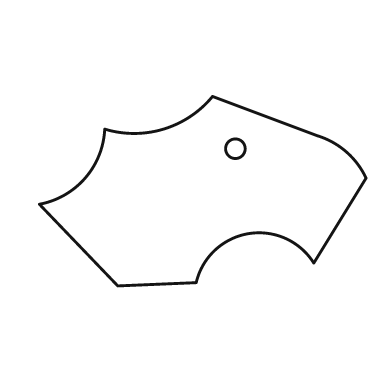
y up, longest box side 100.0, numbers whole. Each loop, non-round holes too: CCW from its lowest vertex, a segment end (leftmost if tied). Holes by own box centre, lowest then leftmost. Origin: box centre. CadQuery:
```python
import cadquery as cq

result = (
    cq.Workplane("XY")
    .moveTo(-26.0, -29.0)
    .lineTo(-2.0, -28.0)
    .threePointArc((14.0, -13.0), (34.0, -22.0))
    .lineTo(50.0, 4.0)
    .threePointArc((44.0, 12.0), (35.0, 17.0))
    .lineTo(3.0, 29.0)
    .threePointArc((-12.0, 19.0), (-30.0, 19.0))
    .threePointArc((-36.0, 4.0), (-50.0, -4.0))
    .close()
    .moveTo(10.0, 13.0)
    .circle(3.0)
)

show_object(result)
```